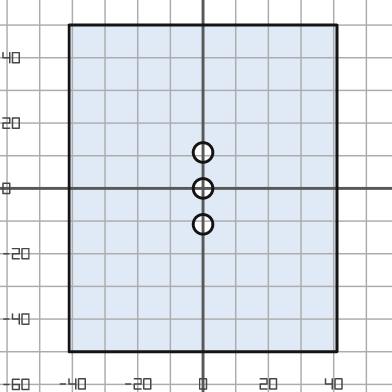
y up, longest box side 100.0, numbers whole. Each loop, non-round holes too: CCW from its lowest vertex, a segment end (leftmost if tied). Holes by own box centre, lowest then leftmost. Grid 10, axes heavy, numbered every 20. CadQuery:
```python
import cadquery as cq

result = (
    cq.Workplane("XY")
    .moveTo(-41.0, -50.0)
    .lineTo(41.0, -50.0)
    .lineTo(41.0, 50.0)
    .lineTo(-41.0, 50.0)
    .close()
    .moveTo(0.0, -11.0)
    .circle(3.0)
    .moveTo(0.0, 0.0)
    .circle(3.0)
    .moveTo(0.0, 11.0)
    .circle(3.0)
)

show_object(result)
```